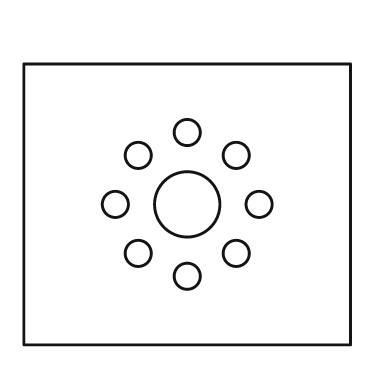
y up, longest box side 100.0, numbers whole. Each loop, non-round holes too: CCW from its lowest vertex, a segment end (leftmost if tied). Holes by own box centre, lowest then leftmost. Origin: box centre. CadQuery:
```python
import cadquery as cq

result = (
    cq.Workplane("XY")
    .moveTo(-50.0, -43.0)
    .lineTo(50.0, -43.0)
    .lineTo(50.0, 43.0)
    .lineTo(-50.0, 43.0)
    .close()
    .moveTo(0.0, -22.0)
    .circle(4.0)
    .moveTo(-15.0, -15.0)
    .circle(4.0)
    .moveTo(15.0, -15.0)
    .circle(4.0)
    .moveTo(-22.0, 0.0)
    .circle(4.0)
    .moveTo(0.0, 0.0)
    .circle(10.0)
    .moveTo(22.0, 0.0)
    .circle(4.0)
    .moveTo(-15.0, 15.0)
    .circle(4.0)
    .moveTo(15.0, 15.0)
    .circle(4.0)
    .moveTo(0.0, 22.0)
    .circle(4.0)
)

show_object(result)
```